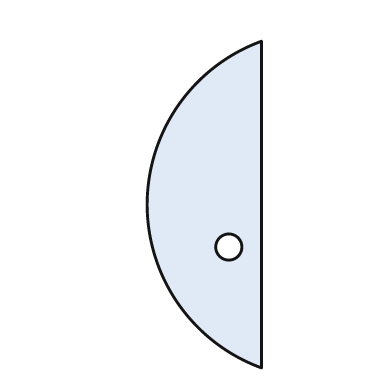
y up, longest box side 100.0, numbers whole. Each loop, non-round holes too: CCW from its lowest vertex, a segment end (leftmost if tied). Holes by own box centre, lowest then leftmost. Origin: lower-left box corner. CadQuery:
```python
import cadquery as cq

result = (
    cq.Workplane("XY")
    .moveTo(35.0, 0.0)
    .lineTo(35.0, 100.0)
    .threePointArc((0.0, 50.0), (35.0, 0.0))
    .close()
    .moveTo(25.0, 37.0)
    .circle(4.0)
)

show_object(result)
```